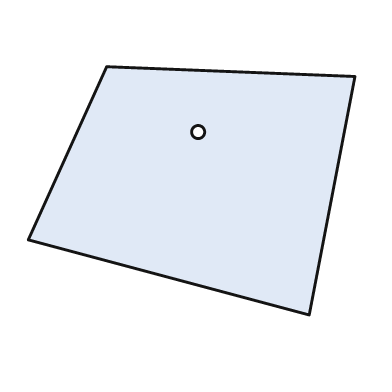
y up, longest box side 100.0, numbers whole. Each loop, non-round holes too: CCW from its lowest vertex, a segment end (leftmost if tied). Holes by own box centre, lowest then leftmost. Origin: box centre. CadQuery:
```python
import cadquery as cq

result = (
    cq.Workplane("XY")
    .moveTo(36.0, -38.0)
    .lineTo(50.0, 35.0)
    .lineTo(-26.0, 38.0)
    .lineTo(-50.0, -15.0)
    .close()
    .moveTo(2.0, 18.0)
    .circle(2.0)
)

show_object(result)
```